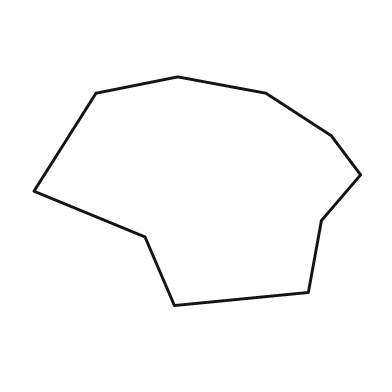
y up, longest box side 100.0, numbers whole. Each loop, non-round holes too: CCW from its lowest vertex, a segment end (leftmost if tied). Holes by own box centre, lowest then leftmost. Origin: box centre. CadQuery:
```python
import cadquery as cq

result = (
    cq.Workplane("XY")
    .moveTo(-7.0, -35.0)
    .lineTo(34.0, -31.0)
    .lineTo(38.0, -9.0)
    .lineTo(50.0, 5.0)
    .lineTo(41.0, 17.0)
    .lineTo(21.0, 30.0)
    .lineTo(-6.0, 35.0)
    .lineTo(-31.0, 30.0)
    .lineTo(-50.0, 0.0)
    .lineTo(-16.0, -14.0)
    .close()
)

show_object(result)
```